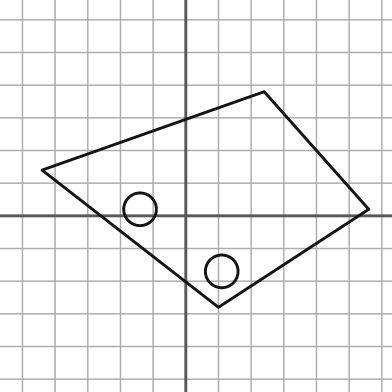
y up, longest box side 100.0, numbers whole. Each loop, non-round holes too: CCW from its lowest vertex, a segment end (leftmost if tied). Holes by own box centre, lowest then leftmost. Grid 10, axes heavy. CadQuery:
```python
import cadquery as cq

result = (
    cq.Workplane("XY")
    .moveTo(10.0, -28.0)
    .lineTo(56.0, 2.0)
    .lineTo(24.0, 38.0)
    .lineTo(-44.0, 14.0)
    .close()
    .moveTo(11.0, -17.0)
    .circle(5.0)
    .moveTo(-14.0, 2.0)
    .circle(5.0)
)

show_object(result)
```